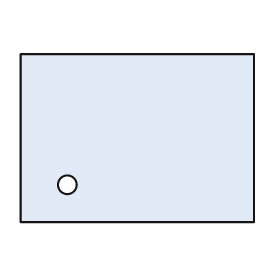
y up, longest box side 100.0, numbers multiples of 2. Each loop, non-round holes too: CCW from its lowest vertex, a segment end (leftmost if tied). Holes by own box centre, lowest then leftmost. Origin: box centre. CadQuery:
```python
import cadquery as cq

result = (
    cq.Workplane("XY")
    .moveTo(-50.0, -36.0)
    .lineTo(50.0, -36.0)
    .lineTo(50.0, 36.0)
    .lineTo(-50.0, 36.0)
    .close()
    .moveTo(-30.0, -20.0)
    .circle(4.0)
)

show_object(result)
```